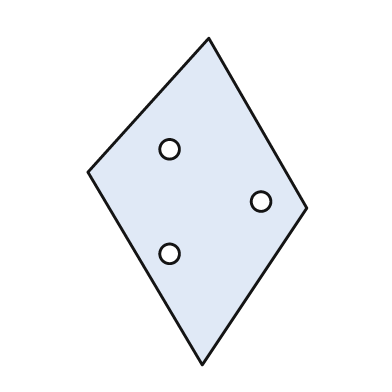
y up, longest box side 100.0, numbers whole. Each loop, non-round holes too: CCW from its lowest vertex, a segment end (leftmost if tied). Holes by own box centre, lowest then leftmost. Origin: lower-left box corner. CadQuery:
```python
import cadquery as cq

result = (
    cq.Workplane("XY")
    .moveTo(35.0, 0.0)
    .lineTo(67.0, 48.0)
    .lineTo(37.0, 100.0)
    .lineTo(0.0, 59.0)
    .close()
    .moveTo(25.0, 34.0)
    .circle(3.0)
    .moveTo(53.0, 50.0)
    .circle(3.0)
    .moveTo(25.0, 66.0)
    .circle(3.0)
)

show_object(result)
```